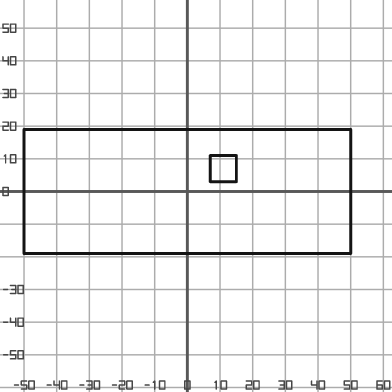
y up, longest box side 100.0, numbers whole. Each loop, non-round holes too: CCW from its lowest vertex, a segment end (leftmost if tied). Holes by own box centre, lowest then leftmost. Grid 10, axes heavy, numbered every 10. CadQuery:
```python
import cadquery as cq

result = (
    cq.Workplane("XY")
    .moveTo(-50.0, -19.0)
    .lineTo(50.0, -19.0)
    .lineTo(50.0, 19.0)
    .lineTo(-50.0, 19.0)
    .close()
    .moveTo(7.0, 3.0)
    .lineTo(15.0, 3.0)
    .lineTo(15.0, 11.0)
    .lineTo(7.0, 11.0)
    .close()
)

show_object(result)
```